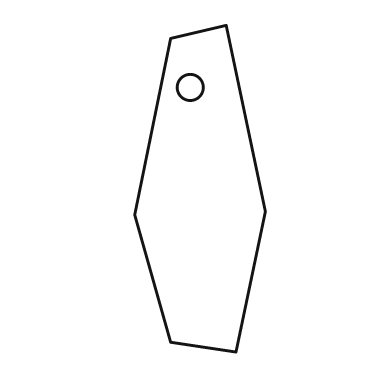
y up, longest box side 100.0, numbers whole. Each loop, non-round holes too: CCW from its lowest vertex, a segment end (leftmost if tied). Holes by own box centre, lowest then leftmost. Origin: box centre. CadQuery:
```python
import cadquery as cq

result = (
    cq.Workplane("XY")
    .moveTo(11.0, -50.0)
    .lineTo(20.0, -7.0)
    .lineTo(8.0, 50.0)
    .lineTo(-9.0, 46.0)
    .lineTo(-20.0, -8.0)
    .lineTo(-9.0, -47.0)
    .close()
    .moveTo(-3.0, 31.0)
    .circle(4.0)
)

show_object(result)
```